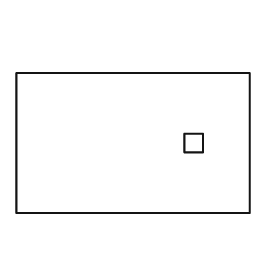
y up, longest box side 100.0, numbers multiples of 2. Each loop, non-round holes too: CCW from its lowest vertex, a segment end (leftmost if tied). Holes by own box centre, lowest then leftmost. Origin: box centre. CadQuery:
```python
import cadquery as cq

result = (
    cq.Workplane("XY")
    .moveTo(-50.0, -30.0)
    .lineTo(50.0, -30.0)
    .lineTo(50.0, 30.0)
    .lineTo(-50.0, 30.0)
    .close()
    .moveTo(22.0, -4.0)
    .lineTo(30.0, -4.0)
    .lineTo(30.0, 4.0)
    .lineTo(22.0, 4.0)
    .close()
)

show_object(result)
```